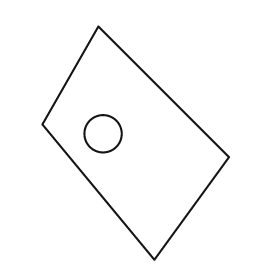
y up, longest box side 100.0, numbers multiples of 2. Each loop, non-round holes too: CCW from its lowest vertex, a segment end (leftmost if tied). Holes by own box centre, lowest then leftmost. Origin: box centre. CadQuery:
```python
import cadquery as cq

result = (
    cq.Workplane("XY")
    .moveTo(8.0, -50.0)
    .lineTo(40.0, -6.0)
    .lineTo(-16.0, 50.0)
    .lineTo(-40.0, 8.0)
    .close()
    .moveTo(-14.0, 4.0)
    .circle(8.0)
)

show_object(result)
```